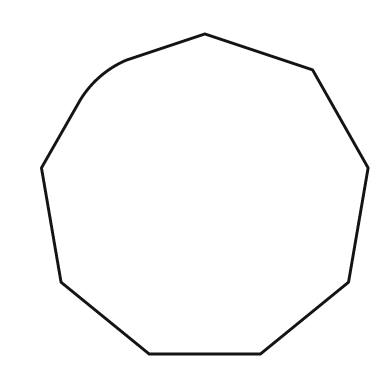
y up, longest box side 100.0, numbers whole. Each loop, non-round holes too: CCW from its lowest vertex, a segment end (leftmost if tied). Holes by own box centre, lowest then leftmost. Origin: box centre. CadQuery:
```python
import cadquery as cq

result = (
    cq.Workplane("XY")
    .moveTo(-17.0, -49.0)
    .lineTo(17.0, -49.0)
    .lineTo(44.0, -27.0)
    .lineTo(50.0, 8.0)
    .lineTo(33.0, 38.0)
    .lineTo(0.0, 49.0)
    .lineTo(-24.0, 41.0)
    .threePointArc((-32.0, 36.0), (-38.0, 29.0))
    .lineTo(-50.0, 8.0)
    .lineTo(-44.0, -27.0)
    .close()
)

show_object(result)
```